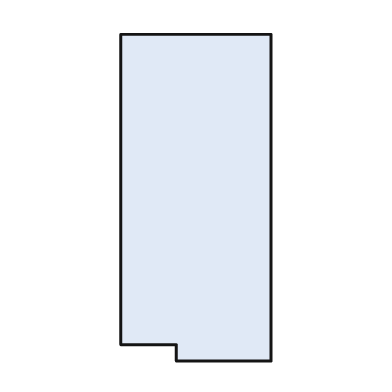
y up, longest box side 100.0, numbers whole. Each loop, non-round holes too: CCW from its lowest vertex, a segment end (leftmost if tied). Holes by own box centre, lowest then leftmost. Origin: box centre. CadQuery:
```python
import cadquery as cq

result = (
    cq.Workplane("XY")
    .moveTo(-6.0, -50.0)
    .lineTo(23.0, -50.0)
    .lineTo(23.0, 50.0)
    .lineTo(-23.0, 50.0)
    .lineTo(-23.0, -45.0)
    .lineTo(-6.0, -45.0)
    .close()
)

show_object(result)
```